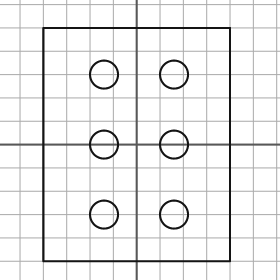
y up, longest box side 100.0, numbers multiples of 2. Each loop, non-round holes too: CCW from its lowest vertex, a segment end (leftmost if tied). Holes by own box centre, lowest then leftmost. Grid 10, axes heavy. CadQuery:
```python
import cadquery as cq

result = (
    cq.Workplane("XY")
    .moveTo(-40.0, -50.0)
    .lineTo(40.0, -50.0)
    .lineTo(40.0, 50.0)
    .lineTo(-40.0, 50.0)
    .close()
    .moveTo(-14.0, -30.0)
    .circle(6.0)
    .moveTo(16.0, -30.0)
    .circle(6.0)
    .moveTo(-14.0, 0.0)
    .circle(6.0)
    .moveTo(16.0, 0.0)
    .circle(6.0)
    .moveTo(-14.0, 30.0)
    .circle(6.0)
    .moveTo(16.0, 30.0)
    .circle(6.0)
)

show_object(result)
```